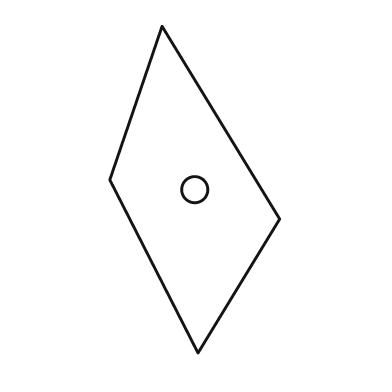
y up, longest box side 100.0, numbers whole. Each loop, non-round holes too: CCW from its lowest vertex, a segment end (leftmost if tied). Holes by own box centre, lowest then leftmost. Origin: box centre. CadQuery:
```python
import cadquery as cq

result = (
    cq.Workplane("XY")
    .moveTo(1.0, -50.0)
    .lineTo(26.0, -9.0)
    .lineTo(-10.0, 50.0)
    .lineTo(-26.0, 3.0)
    .close()
    .moveTo(0.0, 0.0)
    .circle(4.0)
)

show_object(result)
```